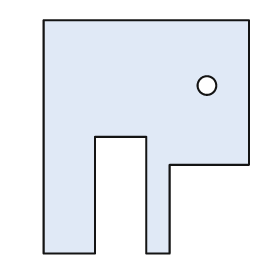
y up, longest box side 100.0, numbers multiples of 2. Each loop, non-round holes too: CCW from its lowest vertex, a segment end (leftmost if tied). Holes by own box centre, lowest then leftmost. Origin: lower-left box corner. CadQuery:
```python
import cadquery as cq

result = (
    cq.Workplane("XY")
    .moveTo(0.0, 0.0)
    .lineTo(22.0, 0.0)
    .lineTo(22.0, 50.0)
    .lineTo(44.0, 50.0)
    .lineTo(44.0, 0.0)
    .lineTo(54.0, 0.0)
    .lineTo(54.0, 38.0)
    .lineTo(88.0, 38.0)
    .lineTo(88.0, 100.0)
    .lineTo(0.0, 100.0)
    .close()
    .moveTo(70.0, 72.0)
    .circle(4.0)
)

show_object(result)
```